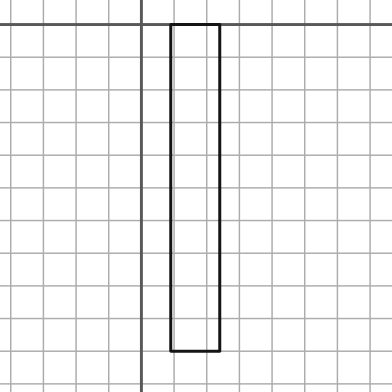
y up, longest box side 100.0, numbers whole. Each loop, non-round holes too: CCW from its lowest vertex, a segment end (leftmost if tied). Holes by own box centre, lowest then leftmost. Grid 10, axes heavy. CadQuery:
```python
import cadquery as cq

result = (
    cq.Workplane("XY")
    .moveTo(9.0, -100.0)
    .lineTo(24.0, -100.0)
    .lineTo(24.0, 0.0)
    .lineTo(9.0, 0.0)
    .close()
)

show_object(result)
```